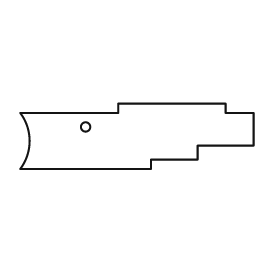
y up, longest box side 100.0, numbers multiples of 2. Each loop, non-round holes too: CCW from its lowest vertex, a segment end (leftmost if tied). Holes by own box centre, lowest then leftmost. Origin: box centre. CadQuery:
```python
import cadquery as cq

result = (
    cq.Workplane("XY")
    .moveTo(-50.0, -14.0)
    .lineTo(6.0, -14.0)
    .lineTo(6.0, -10.0)
    .lineTo(26.0, -10.0)
    .lineTo(26.0, -4.0)
    .lineTo(50.0, -4.0)
    .lineTo(50.0, 10.0)
    .lineTo(38.0, 10.0)
    .lineTo(38.0, 14.0)
    .lineTo(-8.0, 14.0)
    .lineTo(-8.0, 10.0)
    .lineTo(-50.0, 10.0)
    .threePointArc((-46.0, -2.0), (-50.0, -14.0))
    .close()
    .moveTo(-22.0, 4.0)
    .circle(2.0)
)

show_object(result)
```